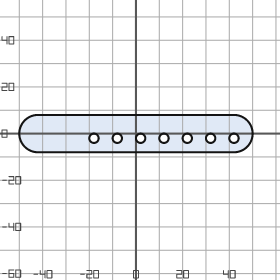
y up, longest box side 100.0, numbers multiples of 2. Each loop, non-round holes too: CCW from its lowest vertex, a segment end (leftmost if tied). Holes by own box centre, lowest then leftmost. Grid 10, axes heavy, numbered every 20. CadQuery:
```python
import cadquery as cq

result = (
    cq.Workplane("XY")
    .moveTo(-42.0, -8.0)
    .lineTo(42.0, -8.0)
    .threePointArc((50.0, 0.0), (42.0, 8.0))
    .lineTo(-42.0, 8.0)
    .threePointArc((-50.0, 0.0), (-42.0, -8.0))
    .close()
    .moveTo(-18.0, -2.0)
    .circle(2.0)
    .moveTo(-8.0, -2.0)
    .circle(2.0)
    .moveTo(2.0, -2.0)
    .circle(2.0)
    .moveTo(12.0, -2.0)
    .circle(2.0)
    .moveTo(22.0, -2.0)
    .circle(2.0)
    .moveTo(32.0, -2.0)
    .circle(2.0)
    .moveTo(42.0, -2.0)
    .circle(2.0)
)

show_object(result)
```